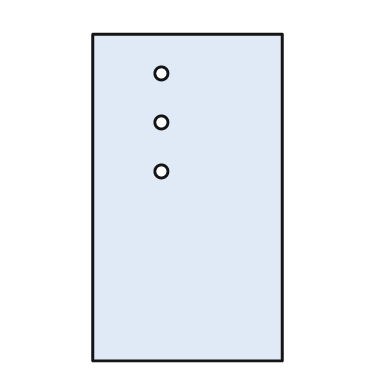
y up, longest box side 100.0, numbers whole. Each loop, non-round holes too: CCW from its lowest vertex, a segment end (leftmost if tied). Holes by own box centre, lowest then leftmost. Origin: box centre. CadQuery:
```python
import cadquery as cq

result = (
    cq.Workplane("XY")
    .moveTo(-29.0, -50.0)
    .lineTo(29.0, -50.0)
    .lineTo(29.0, 50.0)
    .lineTo(-29.0, 50.0)
    .close()
    .moveTo(-8.0, 8.0)
    .circle(2.0)
    .moveTo(-8.0, 23.0)
    .circle(2.0)
    .moveTo(-8.0, 38.0)
    .circle(2.0)
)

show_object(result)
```